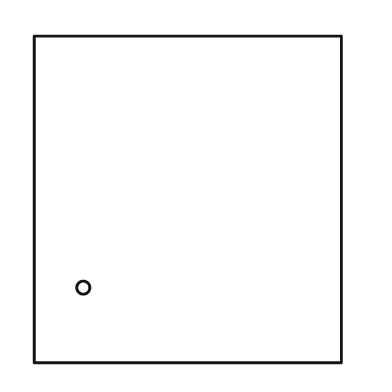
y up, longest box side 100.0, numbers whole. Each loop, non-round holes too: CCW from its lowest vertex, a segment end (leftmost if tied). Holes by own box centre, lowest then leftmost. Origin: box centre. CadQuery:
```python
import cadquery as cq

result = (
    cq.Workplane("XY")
    .moveTo(-47.0, -50.0)
    .lineTo(47.0, -50.0)
    .lineTo(47.0, 50.0)
    .lineTo(-47.0, 50.0)
    .close()
    .moveTo(-32.0, -27.0)
    .circle(2.0)
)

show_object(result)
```